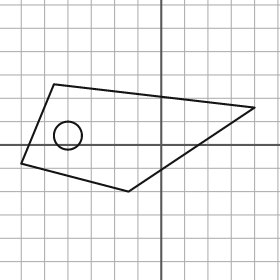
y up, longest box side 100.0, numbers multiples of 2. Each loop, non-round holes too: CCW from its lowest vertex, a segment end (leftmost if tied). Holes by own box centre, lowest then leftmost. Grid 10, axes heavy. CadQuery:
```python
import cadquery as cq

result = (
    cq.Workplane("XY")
    .moveTo(-14.0, -20.0)
    .lineTo(40.0, 16.0)
    .lineTo(-46.0, 26.0)
    .lineTo(-60.0, -8.0)
    .close()
    .moveTo(-40.0, 4.0)
    .circle(6.0)
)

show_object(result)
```